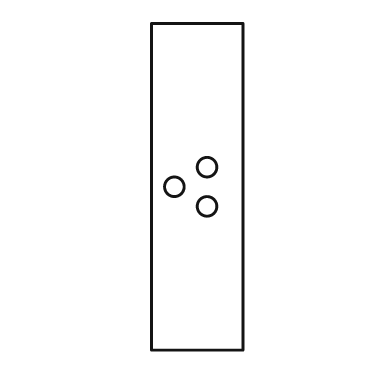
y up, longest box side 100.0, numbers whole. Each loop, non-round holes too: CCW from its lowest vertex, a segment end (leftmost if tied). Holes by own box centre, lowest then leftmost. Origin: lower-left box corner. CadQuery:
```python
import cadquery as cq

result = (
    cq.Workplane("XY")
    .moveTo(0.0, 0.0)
    .lineTo(28.0, 0.0)
    .lineTo(28.0, 100.0)
    .lineTo(0.0, 100.0)
    .close()
    .moveTo(17.0, 44.0)
    .circle(3.0)
    .moveTo(7.0, 50.0)
    .circle(3.0)
    .moveTo(17.0, 56.0)
    .circle(3.0)
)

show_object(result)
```